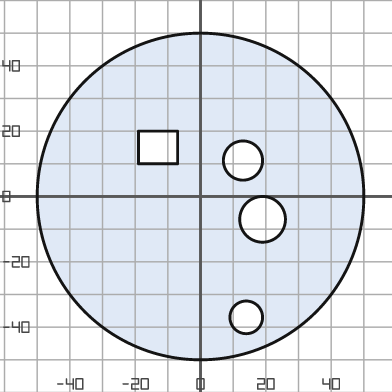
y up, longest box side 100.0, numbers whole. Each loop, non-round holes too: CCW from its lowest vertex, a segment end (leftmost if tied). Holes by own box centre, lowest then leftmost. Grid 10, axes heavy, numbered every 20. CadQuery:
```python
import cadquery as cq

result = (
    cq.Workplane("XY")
    .moveTo(0.0, 0.0)
    .circle(50.0)
    .moveTo(14.0, -37.0)
    .circle(5.0)
    .moveTo(19.0, -7.0)
    .circle(7.0)
    .moveTo(13.0, 11.0)
    .circle(6.0)
    .moveTo(-19.0, 10.0)
    .lineTo(-7.0, 10.0)
    .lineTo(-7.0, 20.0)
    .lineTo(-19.0, 20.0)
    .close()
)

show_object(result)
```